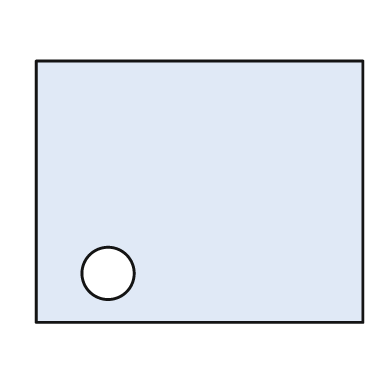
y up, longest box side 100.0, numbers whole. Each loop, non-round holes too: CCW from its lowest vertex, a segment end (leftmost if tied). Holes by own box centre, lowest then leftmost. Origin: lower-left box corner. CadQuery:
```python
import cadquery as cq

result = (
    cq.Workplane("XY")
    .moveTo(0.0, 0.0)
    .lineTo(100.0, 0.0)
    .lineTo(100.0, 80.0)
    .lineTo(0.0, 80.0)
    .close()
    .moveTo(22.0, 15.0)
    .circle(8.0)
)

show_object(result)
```